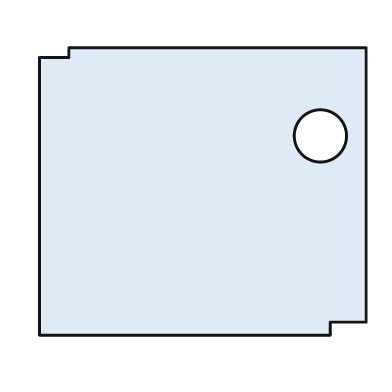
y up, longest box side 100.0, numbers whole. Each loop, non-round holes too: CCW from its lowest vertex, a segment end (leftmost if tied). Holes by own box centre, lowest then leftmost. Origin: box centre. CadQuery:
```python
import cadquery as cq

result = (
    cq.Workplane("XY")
    .moveTo(-50.0, -44.0)
    .lineTo(39.0, -44.0)
    .lineTo(39.0, -40.0)
    .lineTo(50.0, -40.0)
    .lineTo(50.0, 44.0)
    .lineTo(-41.0, 44.0)
    .lineTo(-41.0, 41.0)
    .lineTo(-50.0, 41.0)
    .close()
    .moveTo(36.0, 17.0)
    .circle(8.0)
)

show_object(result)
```